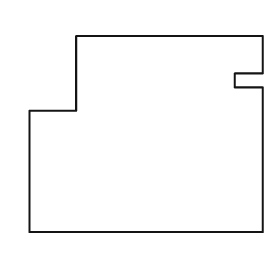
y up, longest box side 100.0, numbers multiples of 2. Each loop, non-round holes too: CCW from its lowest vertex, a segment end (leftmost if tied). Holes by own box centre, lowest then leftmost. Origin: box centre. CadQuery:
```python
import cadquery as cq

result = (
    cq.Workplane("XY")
    .moveTo(-50.0, -42.0)
    .lineTo(50.0, -42.0)
    .lineTo(50.0, 20.0)
    .lineTo(38.0, 20.0)
    .lineTo(38.0, 26.0)
    .lineTo(50.0, 26.0)
    .lineTo(50.0, 42.0)
    .lineTo(-30.0, 42.0)
    .lineTo(-30.0, 10.0)
    .lineTo(-50.0, 10.0)
    .close()
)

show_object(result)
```